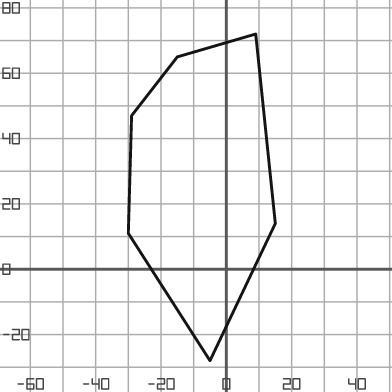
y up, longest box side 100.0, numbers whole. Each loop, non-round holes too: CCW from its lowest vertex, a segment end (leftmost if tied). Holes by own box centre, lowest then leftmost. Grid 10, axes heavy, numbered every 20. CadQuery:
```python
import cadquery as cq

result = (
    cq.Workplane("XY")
    .moveTo(-5.0, -28.0)
    .lineTo(15.0, 14.0)
    .lineTo(9.0, 72.0)
    .lineTo(-15.0, 65.0)
    .lineTo(-29.0, 47.0)
    .lineTo(-30.0, 11.0)
    .close()
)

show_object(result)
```